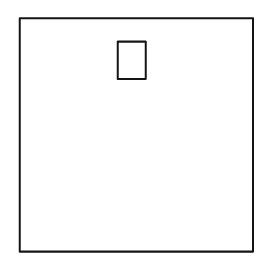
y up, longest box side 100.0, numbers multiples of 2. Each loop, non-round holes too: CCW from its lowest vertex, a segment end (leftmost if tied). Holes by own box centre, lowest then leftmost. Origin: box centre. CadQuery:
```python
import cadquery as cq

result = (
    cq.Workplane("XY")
    .moveTo(-50.0, -50.0)
    .lineTo(50.0, -50.0)
    .lineTo(50.0, 50.0)
    .lineTo(-50.0, 50.0)
    .close()
    .moveTo(-8.0, 24.0)
    .lineTo(4.0, 24.0)
    .lineTo(4.0, 40.0)
    .lineTo(-8.0, 40.0)
    .close()
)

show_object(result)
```